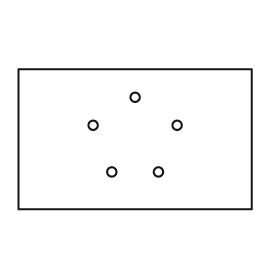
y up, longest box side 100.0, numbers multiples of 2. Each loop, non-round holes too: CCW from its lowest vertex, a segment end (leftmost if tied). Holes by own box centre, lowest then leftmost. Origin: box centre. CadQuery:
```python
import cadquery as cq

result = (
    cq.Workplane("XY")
    .moveTo(-50.0, -30.0)
    .lineTo(50.0, -30.0)
    .lineTo(50.0, 30.0)
    .lineTo(-50.0, 30.0)
    .close()
    .moveTo(-10.0, -14.0)
    .circle(2.0)
    .moveTo(10.0, -14.0)
    .circle(2.0)
    .moveTo(-18.0, 6.0)
    .circle(2.0)
    .moveTo(18.0, 6.0)
    .circle(2.0)
    .moveTo(0.0, 18.0)
    .circle(2.0)
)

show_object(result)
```